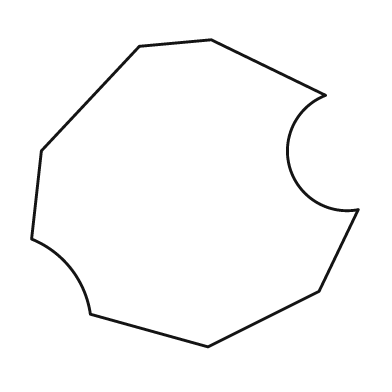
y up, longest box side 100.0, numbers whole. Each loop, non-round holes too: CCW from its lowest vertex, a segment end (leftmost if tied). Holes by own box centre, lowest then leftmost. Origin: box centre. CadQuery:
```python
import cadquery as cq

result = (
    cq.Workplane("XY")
    .moveTo(4.0, -47.0)
    .lineTo(38.0, -30.0)
    .lineTo(50.0, -5.0)
    .threePointArc((29.0, 8.0), (40.0, 30.0))
    .lineTo(5.0, 47.0)
    .lineTo(-17.0, 45.0)
    .lineTo(-47.0, 13.0)
    .lineTo(-50.0, -14.0)
    .threePointArc((-38.0, -23.0), (-32.0, -37.0))
    .close()
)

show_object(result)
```